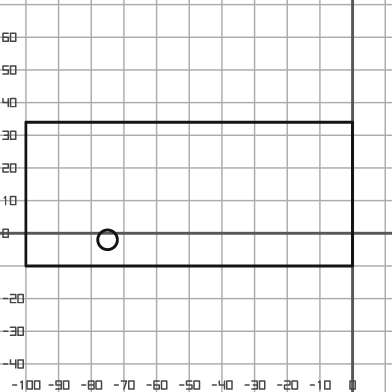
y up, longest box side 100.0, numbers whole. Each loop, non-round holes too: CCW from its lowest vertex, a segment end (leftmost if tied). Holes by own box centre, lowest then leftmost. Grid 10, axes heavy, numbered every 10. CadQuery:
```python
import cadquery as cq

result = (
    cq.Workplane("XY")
    .moveTo(-100.0, -10.0)
    .lineTo(0.0, -10.0)
    .lineTo(0.0, 34.0)
    .lineTo(-100.0, 34.0)
    .close()
    .moveTo(-75.0, -2.0)
    .circle(3.0)
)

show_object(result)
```